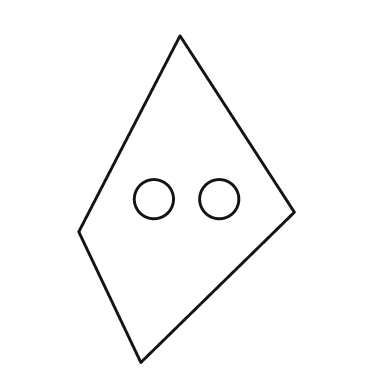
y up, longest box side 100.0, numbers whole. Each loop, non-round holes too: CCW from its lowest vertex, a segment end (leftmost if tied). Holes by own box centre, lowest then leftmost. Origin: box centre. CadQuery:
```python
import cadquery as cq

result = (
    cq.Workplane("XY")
    .moveTo(-14.0, -50.0)
    .lineTo(33.0, -4.0)
    .lineTo(-2.0, 50.0)
    .lineTo(-33.0, -10.0)
    .close()
    .moveTo(-10.0, 0.0)
    .circle(6.0)
    .moveTo(10.0, 0.0)
    .circle(6.0)
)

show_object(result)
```